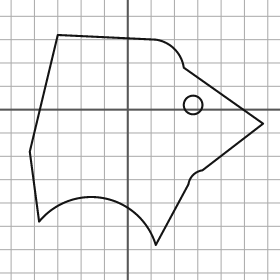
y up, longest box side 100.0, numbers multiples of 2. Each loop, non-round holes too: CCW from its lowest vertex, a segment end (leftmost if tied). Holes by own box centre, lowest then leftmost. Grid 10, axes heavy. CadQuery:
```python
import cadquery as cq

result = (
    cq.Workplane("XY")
    .moveTo(12.0, -58.0)
    .lineTo(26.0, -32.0)
    .threePointArc((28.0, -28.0), (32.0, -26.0))
    .lineTo(58.0, -6.0)
    .lineTo(24.0, 18.0)
    .threePointArc((20.0, 26.0), (12.0, 30.0))
    .lineTo(-30.0, 32.0)
    .lineTo(-42.0, -18.0)
    .lineTo(-38.0, -48.0)
    .threePointArc((-10.0, -38.0), (12.0, -58.0))
    .close()
    .moveTo(28.0, 2.0)
    .circle(4.0)
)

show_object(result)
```